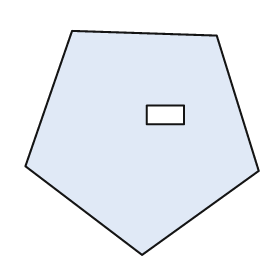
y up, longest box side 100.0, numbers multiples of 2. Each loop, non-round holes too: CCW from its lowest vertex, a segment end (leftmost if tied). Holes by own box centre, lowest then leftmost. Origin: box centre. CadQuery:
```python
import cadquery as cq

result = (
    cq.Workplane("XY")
    .moveTo(0.0, -48.0)
    .lineTo(50.0, -12.0)
    .lineTo(32.0, 46.0)
    .lineTo(-30.0, 48.0)
    .lineTo(-50.0, -10.0)
    .close()
    .moveTo(2.0, 8.0)
    .lineTo(18.0, 8.0)
    .lineTo(18.0, 16.0)
    .lineTo(2.0, 16.0)
    .close()
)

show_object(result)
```